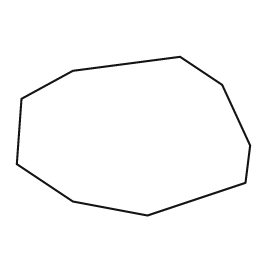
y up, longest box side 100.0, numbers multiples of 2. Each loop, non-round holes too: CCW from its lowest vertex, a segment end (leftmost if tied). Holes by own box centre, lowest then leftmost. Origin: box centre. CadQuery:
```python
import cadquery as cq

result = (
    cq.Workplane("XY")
    .moveTo(6.0, -34.0)
    .lineTo(48.0, -20.0)
    .lineTo(50.0, -4.0)
    .lineTo(38.0, 22.0)
    .lineTo(20.0, 34.0)
    .lineTo(-26.0, 28.0)
    .lineTo(-48.0, 16.0)
    .lineTo(-50.0, -12.0)
    .lineTo(-26.0, -28.0)
    .close()
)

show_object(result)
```